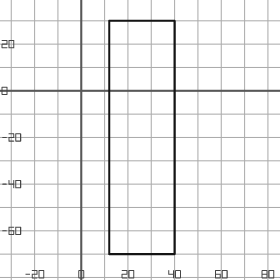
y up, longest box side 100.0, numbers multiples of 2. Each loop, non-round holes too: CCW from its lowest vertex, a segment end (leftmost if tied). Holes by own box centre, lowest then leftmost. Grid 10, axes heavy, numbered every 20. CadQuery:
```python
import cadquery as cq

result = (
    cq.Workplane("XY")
    .moveTo(12.0, -70.0)
    .lineTo(40.0, -70.0)
    .lineTo(40.0, 30.0)
    .lineTo(12.0, 30.0)
    .close()
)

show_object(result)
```